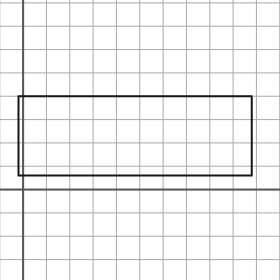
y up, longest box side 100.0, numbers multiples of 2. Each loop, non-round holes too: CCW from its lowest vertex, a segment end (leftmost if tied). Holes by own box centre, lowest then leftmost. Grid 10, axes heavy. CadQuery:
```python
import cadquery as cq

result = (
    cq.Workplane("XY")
    .moveTo(-2.0, 6.0)
    .lineTo(98.0, 6.0)
    .lineTo(98.0, 40.0)
    .lineTo(-2.0, 40.0)
    .close()
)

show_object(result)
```